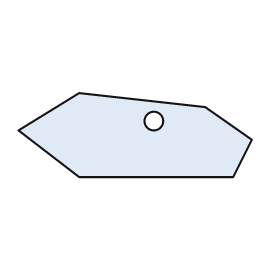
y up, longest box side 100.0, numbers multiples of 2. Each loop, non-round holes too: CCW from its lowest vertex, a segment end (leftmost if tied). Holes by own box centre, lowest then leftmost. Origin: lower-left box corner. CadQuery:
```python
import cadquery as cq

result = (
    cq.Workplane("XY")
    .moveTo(26.0, 0.0)
    .lineTo(92.0, 0.0)
    .lineTo(100.0, 16.0)
    .lineTo(80.0, 30.0)
    .lineTo(26.0, 36.0)
    .lineTo(0.0, 20.0)
    .close()
    .moveTo(58.0, 24.0)
    .circle(4.0)
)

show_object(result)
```